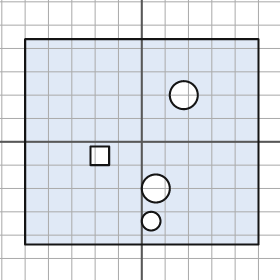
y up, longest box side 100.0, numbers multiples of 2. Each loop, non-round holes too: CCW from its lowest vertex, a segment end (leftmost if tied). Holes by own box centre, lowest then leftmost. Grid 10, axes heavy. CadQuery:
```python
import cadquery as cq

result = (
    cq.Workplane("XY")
    .moveTo(-50.0, -44.0)
    .lineTo(50.0, -44.0)
    .lineTo(50.0, 44.0)
    .lineTo(-50.0, 44.0)
    .close()
    .moveTo(4.0, -34.0)
    .circle(4.0)
    .moveTo(6.0, -20.0)
    .circle(6.0)
    .moveTo(-22.0, -10.0)
    .lineTo(-14.0, -10.0)
    .lineTo(-14.0, -2.0)
    .lineTo(-22.0, -2.0)
    .close()
    .moveTo(18.0, 20.0)
    .circle(6.0)
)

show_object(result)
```